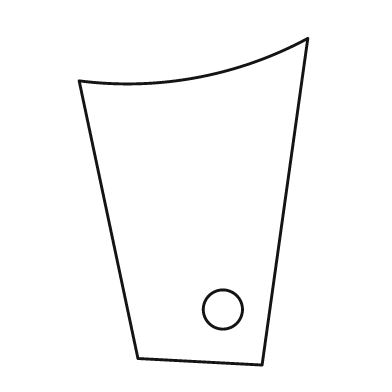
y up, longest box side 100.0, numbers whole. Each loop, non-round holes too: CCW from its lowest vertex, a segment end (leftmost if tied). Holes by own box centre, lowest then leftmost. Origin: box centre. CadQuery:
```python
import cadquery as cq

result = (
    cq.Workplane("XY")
    .moveTo(21.0, -50.0)
    .lineTo(35.0, 50.0)
    .threePointArc((1.0, 38.0), (-35.0, 37.0))
    .lineTo(-17.0, -48.0)
    .close()
    .moveTo(9.0, -33.0)
    .circle(6.0)
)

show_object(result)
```